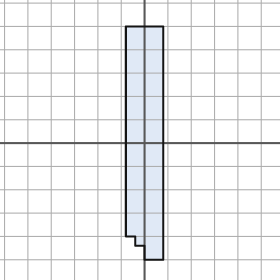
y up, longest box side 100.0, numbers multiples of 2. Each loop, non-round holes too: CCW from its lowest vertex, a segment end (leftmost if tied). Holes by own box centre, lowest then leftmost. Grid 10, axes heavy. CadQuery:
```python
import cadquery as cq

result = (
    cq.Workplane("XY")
    .moveTo(0.0, -50.0)
    .lineTo(8.0, -50.0)
    .lineTo(8.0, 50.0)
    .lineTo(-8.0, 50.0)
    .lineTo(-8.0, -40.0)
    .lineTo(-4.0, -40.0)
    .lineTo(-4.0, -44.0)
    .lineTo(0.0, -44.0)
    .close()
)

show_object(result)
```